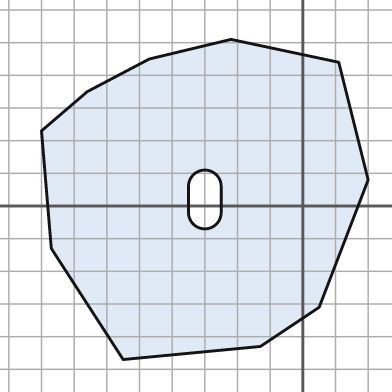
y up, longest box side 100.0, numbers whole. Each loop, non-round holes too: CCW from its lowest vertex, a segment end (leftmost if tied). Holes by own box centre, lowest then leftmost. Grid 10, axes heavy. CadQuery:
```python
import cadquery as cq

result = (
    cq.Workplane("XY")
    .moveTo(-55.0, -47.0)
    .lineTo(-13.0, -43.0)
    .lineTo(5.0, -31.0)
    .lineTo(20.0, 8.0)
    .lineTo(11.0, 44.0)
    .lineTo(-22.0, 51.0)
    .lineTo(-47.0, 45.0)
    .lineTo(-66.0, 35.0)
    .lineTo(-80.0, 23.0)
    .lineTo(-77.0, -13.0)
    .close()
    .moveTo(-35.0, -2.0)
    .threePointArc((-30.0, -7.0), (-25.0, -2.0))
    .lineTo(-25.0, 6.0)
    .threePointArc((-30.0, 11.0), (-35.0, 6.0))
    .close()
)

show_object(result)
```